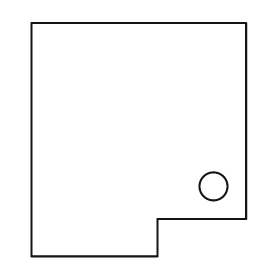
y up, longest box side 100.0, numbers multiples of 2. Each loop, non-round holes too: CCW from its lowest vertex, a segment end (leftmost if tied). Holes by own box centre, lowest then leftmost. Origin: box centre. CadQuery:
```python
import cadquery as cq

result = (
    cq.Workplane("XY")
    .moveTo(-46.0, -50.0)
    .lineTo(8.0, -50.0)
    .lineTo(8.0, -34.0)
    .lineTo(46.0, -34.0)
    .lineTo(46.0, 50.0)
    .lineTo(-46.0, 50.0)
    .close()
    .moveTo(32.0, -20.0)
    .circle(6.0)
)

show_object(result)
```